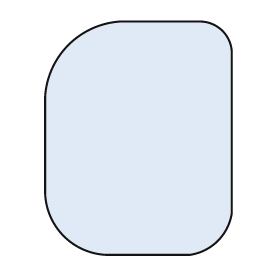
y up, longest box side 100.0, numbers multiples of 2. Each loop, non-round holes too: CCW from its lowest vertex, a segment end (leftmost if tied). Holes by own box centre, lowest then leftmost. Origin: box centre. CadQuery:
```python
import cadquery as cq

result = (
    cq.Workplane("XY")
    .moveTo(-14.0, -50.0)
    .lineTo(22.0, -50.0)
    .threePointArc((34.0, -44.0), (40.0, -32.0))
    .lineTo(40.0, 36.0)
    .threePointArc((36.0, 46.0), (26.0, 50.0))
    .lineTo(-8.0, 50.0)
    .threePointArc((-30.0, 40.0), (-40.0, 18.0))
    .lineTo(-40.0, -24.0)
    .threePointArc((-32.0, -42.0), (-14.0, -50.0))
    .close()
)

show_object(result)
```